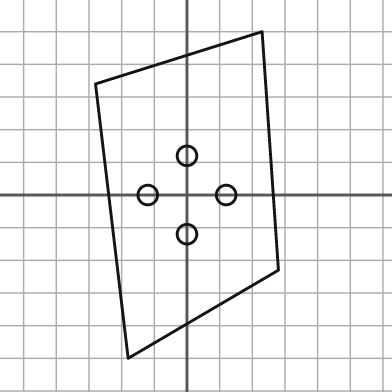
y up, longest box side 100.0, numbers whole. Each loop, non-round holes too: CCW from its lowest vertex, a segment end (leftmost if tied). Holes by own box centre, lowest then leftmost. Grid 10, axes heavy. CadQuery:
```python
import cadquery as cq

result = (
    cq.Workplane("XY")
    .moveTo(-18.0, -50.0)
    .lineTo(28.0, -23.0)
    .lineTo(23.0, 50.0)
    .lineTo(-28.0, 34.0)
    .close()
    .moveTo(0.0, -12.0)
    .circle(3.0)
    .moveTo(-12.0, 0.0)
    .circle(3.0)
    .moveTo(12.0, 0.0)
    .circle(3.0)
    .moveTo(0.0, 12.0)
    .circle(3.0)
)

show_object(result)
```